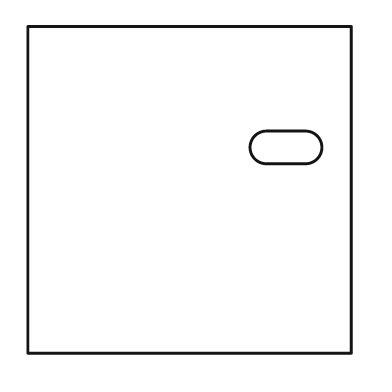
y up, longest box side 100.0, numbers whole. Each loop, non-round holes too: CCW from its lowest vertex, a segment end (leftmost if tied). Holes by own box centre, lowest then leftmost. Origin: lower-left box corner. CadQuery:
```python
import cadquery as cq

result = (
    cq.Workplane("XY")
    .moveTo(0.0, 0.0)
    .lineTo(99.0, 0.0)
    .lineTo(99.0, 100.0)
    .lineTo(0.0, 100.0)
    .close()
    .moveTo(73.0, 58.0)
    .lineTo(85.0, 58.0)
    .threePointArc((90.0, 63.0), (85.0, 68.0))
    .lineTo(73.0, 68.0)
    .threePointArc((68.0, 63.0), (73.0, 58.0))
    .close()
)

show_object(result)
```